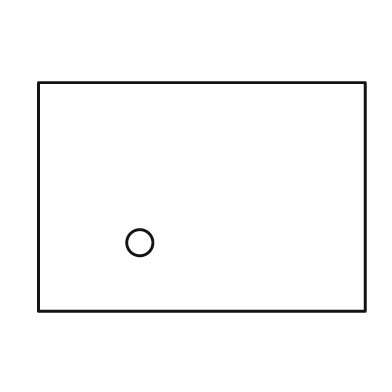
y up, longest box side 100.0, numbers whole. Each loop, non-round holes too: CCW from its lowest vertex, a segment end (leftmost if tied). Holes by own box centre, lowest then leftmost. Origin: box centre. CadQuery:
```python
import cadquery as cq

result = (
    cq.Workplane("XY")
    .moveTo(-50.0, -35.0)
    .lineTo(50.0, -35.0)
    .lineTo(50.0, 35.0)
    .lineTo(-50.0, 35.0)
    .close()
    .moveTo(-19.0, -14.0)
    .circle(4.0)
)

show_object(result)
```